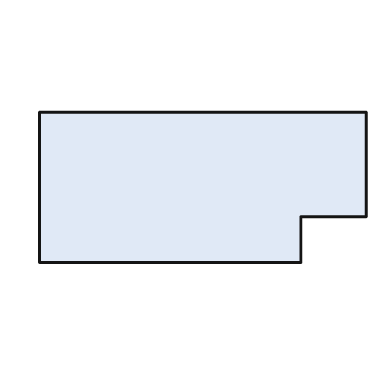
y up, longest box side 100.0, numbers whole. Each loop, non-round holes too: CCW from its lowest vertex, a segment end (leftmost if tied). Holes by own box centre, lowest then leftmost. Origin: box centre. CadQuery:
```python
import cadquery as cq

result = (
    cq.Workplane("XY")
    .moveTo(-50.0, -23.0)
    .lineTo(30.0, -23.0)
    .lineTo(30.0, -9.0)
    .lineTo(50.0, -9.0)
    .lineTo(50.0, 23.0)
    .lineTo(-50.0, 23.0)
    .close()
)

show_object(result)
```